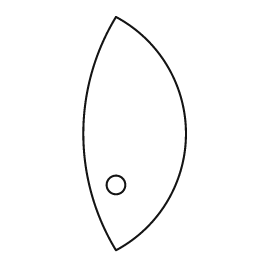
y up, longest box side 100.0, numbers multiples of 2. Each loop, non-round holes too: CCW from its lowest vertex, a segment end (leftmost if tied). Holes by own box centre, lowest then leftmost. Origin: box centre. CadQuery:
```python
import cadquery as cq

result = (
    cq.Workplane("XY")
    .moveTo(-8.0, -50.0)
    .threePointArc((22.0, 0.0), (-8.0, 50.0))
    .threePointArc((-22.0, 0.0), (-8.0, -50.0))
    .close()
    .moveTo(-8.0, -22.0)
    .circle(4.0)
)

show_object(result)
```